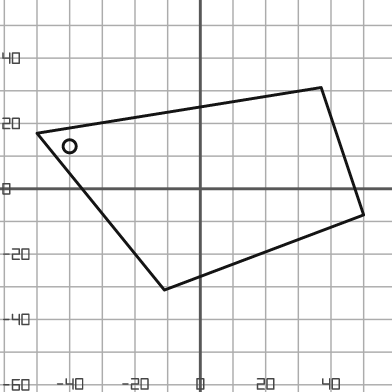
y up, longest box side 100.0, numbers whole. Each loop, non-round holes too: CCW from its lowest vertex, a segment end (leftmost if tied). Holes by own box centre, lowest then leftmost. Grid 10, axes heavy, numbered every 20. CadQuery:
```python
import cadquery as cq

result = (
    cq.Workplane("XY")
    .moveTo(-11.0, -31.0)
    .lineTo(50.0, -8.0)
    .lineTo(37.0, 31.0)
    .lineTo(-50.0, 17.0)
    .close()
    .moveTo(-40.0, 13.0)
    .circle(2.0)
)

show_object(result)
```